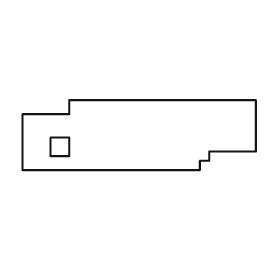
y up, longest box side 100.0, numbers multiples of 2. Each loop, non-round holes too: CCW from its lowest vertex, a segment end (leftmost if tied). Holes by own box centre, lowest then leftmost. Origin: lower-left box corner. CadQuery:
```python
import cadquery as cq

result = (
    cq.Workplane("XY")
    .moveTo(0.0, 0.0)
    .lineTo(76.0, 0.0)
    .lineTo(76.0, 4.0)
    .lineTo(80.0, 4.0)
    .lineTo(80.0, 8.0)
    .lineTo(100.0, 8.0)
    .lineTo(100.0, 30.0)
    .lineTo(20.0, 30.0)
    .lineTo(20.0, 24.0)
    .lineTo(0.0, 24.0)
    .close()
    .moveTo(12.0, 6.0)
    .lineTo(20.0, 6.0)
    .lineTo(20.0, 14.0)
    .lineTo(12.0, 14.0)
    .close()
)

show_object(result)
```